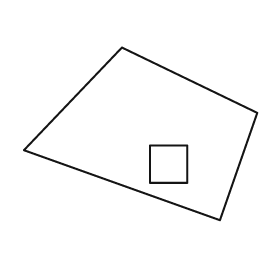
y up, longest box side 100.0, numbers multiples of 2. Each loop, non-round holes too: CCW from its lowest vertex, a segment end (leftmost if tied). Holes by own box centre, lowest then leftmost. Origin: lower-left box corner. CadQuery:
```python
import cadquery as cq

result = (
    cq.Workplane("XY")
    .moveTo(84.0, 0.0)
    .lineTo(100.0, 46.0)
    .lineTo(42.0, 74.0)
    .lineTo(0.0, 30.0)
    .close()
    .moveTo(54.0, 16.0)
    .lineTo(70.0, 16.0)
    .lineTo(70.0, 32.0)
    .lineTo(54.0, 32.0)
    .close()
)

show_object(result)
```